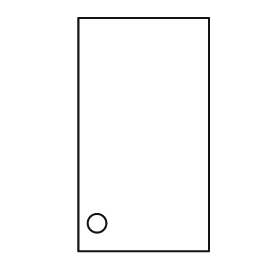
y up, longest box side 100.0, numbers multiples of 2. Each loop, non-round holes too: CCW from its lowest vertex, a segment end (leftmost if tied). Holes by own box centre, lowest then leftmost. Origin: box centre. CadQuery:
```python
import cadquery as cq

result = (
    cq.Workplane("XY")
    .moveTo(-28.0, -50.0)
    .lineTo(28.0, -50.0)
    .lineTo(28.0, 50.0)
    .lineTo(-28.0, 50.0)
    .close()
    .moveTo(-20.0, -38.0)
    .circle(4.0)
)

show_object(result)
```